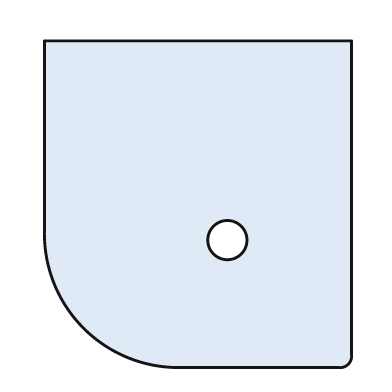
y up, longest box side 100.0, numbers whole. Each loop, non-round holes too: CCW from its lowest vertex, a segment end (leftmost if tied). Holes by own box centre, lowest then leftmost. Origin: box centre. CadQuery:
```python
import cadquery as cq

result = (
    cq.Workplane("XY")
    .moveTo(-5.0, -50.0)
    .lineTo(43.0, -50.0)
    .threePointArc((46.0, -49.0), (47.0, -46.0))
    .lineTo(47.0, 50.0)
    .lineTo(-47.0, 50.0)
    .lineTo(-47.0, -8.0)
    .threePointArc((-35.0, -38.0), (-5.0, -50.0))
    .close()
    .moveTo(9.0, -11.0)
    .circle(6.0)
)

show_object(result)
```